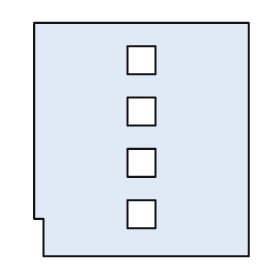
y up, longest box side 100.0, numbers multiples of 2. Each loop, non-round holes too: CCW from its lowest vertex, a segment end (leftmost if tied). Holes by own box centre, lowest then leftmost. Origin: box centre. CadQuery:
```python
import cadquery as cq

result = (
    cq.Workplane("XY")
    .moveTo(-42.0, -50.0)
    .lineTo(46.0, -50.0)
    .lineTo(46.0, 50.0)
    .lineTo(-46.0, 50.0)
    .lineTo(-46.0, -34.0)
    .lineTo(-42.0, -34.0)
    .close()
    .moveTo(-6.0, -38.0)
    .lineTo(6.0, -38.0)
    .lineTo(6.0, -26.0)
    .lineTo(-6.0, -26.0)
    .close()
    .moveTo(-6.0, -16.0)
    .lineTo(6.0, -16.0)
    .lineTo(6.0, -4.0)
    .lineTo(-6.0, -4.0)
    .close()
    .moveTo(-6.0, 6.0)
    .lineTo(6.0, 6.0)
    .lineTo(6.0, 18.0)
    .lineTo(-6.0, 18.0)
    .close()
    .moveTo(-6.0, 28.0)
    .lineTo(6.0, 28.0)
    .lineTo(6.0, 40.0)
    .lineTo(-6.0, 40.0)
    .close()
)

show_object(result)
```